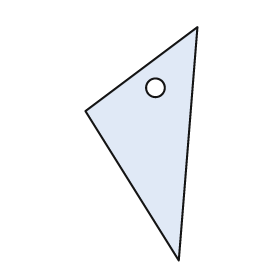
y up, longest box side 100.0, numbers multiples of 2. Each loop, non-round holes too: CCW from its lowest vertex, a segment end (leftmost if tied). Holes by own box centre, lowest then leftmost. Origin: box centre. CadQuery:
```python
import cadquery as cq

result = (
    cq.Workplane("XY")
    .moveTo(16.0, -50.0)
    .lineTo(24.0, 50.0)
    .lineTo(-24.0, 14.0)
    .close()
    .moveTo(6.0, 24.0)
    .circle(4.0)
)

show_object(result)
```